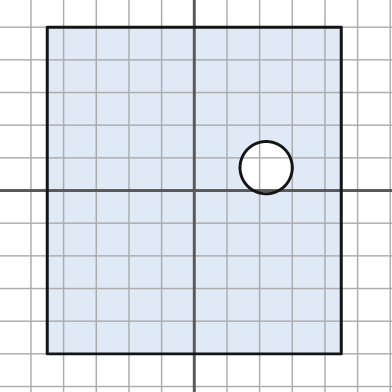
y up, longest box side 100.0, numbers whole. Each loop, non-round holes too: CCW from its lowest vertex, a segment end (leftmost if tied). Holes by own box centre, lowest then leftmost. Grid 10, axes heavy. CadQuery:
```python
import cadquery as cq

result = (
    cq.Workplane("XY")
    .moveTo(-45.0, -50.0)
    .lineTo(45.0, -50.0)
    .lineTo(45.0, 50.0)
    .lineTo(-45.0, 50.0)
    .close()
    .moveTo(22.0, 7.0)
    .circle(8.0)
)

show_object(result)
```